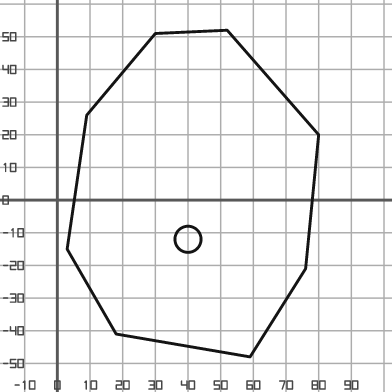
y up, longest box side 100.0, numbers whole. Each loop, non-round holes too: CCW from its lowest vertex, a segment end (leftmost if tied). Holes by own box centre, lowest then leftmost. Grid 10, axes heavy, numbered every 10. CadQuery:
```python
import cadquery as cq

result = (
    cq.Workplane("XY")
    .moveTo(59.0, -48.0)
    .lineTo(76.0, -21.0)
    .lineTo(80.0, 20.0)
    .lineTo(52.0, 52.0)
    .lineTo(30.0, 51.0)
    .lineTo(9.0, 26.0)
    .lineTo(3.0, -15.0)
    .lineTo(18.0, -41.0)
    .close()
    .moveTo(40.0, -12.0)
    .circle(4.0)
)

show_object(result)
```